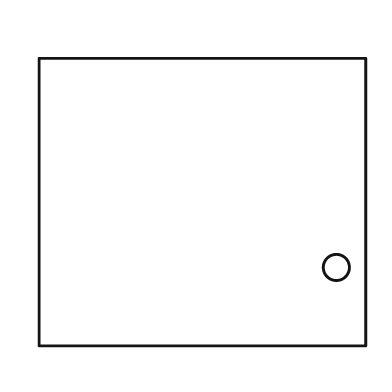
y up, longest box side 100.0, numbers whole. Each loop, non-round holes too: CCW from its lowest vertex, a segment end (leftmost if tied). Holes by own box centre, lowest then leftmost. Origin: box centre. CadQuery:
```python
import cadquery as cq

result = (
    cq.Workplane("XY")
    .moveTo(-50.0, -44.0)
    .lineTo(50.0, -44.0)
    .lineTo(50.0, 44.0)
    .lineTo(-50.0, 44.0)
    .close()
    .moveTo(41.0, -20.0)
    .circle(4.0)
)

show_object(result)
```